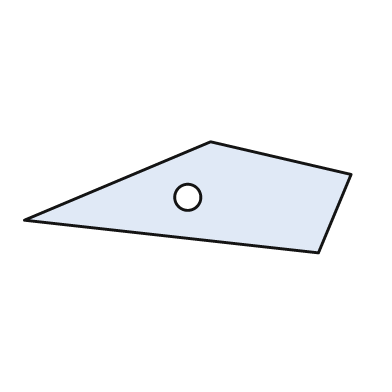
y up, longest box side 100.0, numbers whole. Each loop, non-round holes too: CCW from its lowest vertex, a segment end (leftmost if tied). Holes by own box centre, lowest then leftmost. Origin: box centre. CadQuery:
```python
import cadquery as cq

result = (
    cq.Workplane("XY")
    .moveTo(40.0, -17.0)
    .lineTo(50.0, 7.0)
    .lineTo(7.0, 17.0)
    .lineTo(-50.0, -7.0)
    .close()
    .moveTo(0.0, 0.0)
    .circle(4.0)
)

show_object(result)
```